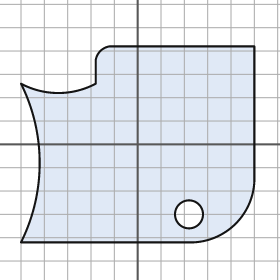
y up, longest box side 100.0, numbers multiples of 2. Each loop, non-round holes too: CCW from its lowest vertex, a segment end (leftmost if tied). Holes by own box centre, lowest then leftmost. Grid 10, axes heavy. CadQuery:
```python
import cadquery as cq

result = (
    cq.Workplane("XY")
    .moveTo(-50.0, -42.0)
    .lineTo(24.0, -42.0)
    .threePointArc((42.0, -34.0), (50.0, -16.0))
    .lineTo(50.0, 42.0)
    .lineTo(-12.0, 42.0)
    .threePointArc((-16.0, 40.0), (-18.0, 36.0))
    .lineTo(-18.0, 26.0)
    .threePointArc((-34.0, 22.0), (-50.0, 26.0))
    .threePointArc((-42.0, -8.0), (-50.0, -42.0))
    .close()
    .moveTo(22.0, -30.0)
    .circle(6.0)
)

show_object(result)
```